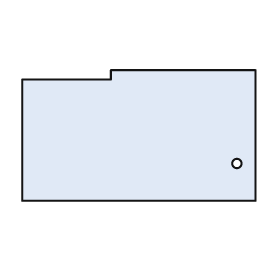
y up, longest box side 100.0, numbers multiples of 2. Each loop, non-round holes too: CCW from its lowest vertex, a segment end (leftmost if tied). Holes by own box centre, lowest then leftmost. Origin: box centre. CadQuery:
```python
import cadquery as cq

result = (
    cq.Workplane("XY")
    .moveTo(-50.0, -28.0)
    .lineTo(50.0, -28.0)
    .lineTo(50.0, 28.0)
    .lineTo(-12.0, 28.0)
    .lineTo(-12.0, 24.0)
    .lineTo(-50.0, 24.0)
    .close()
    .moveTo(42.0, -12.0)
    .circle(2.0)
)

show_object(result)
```